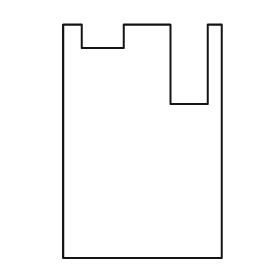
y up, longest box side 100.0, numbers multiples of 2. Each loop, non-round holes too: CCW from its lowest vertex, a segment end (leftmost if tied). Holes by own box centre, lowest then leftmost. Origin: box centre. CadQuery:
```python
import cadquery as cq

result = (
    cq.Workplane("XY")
    .moveTo(-34.0, -50.0)
    .lineTo(34.0, -50.0)
    .lineTo(34.0, 50.0)
    .lineTo(28.0, 50.0)
    .lineTo(28.0, 16.0)
    .lineTo(12.0, 16.0)
    .lineTo(12.0, 50.0)
    .lineTo(-8.0, 50.0)
    .lineTo(-8.0, 40.0)
    .lineTo(-26.0, 40.0)
    .lineTo(-26.0, 50.0)
    .lineTo(-34.0, 50.0)
    .close()
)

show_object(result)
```